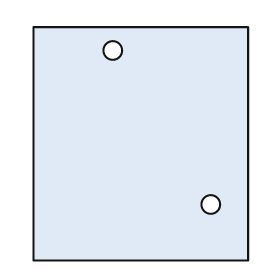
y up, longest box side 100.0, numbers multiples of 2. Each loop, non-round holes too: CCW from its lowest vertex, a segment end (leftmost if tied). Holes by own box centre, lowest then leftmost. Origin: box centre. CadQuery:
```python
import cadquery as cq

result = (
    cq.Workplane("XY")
    .moveTo(-46.0, -50.0)
    .lineTo(46.0, -50.0)
    .lineTo(46.0, 50.0)
    .lineTo(-46.0, 50.0)
    .close()
    .moveTo(30.0, -26.0)
    .circle(4.0)
    .moveTo(-12.0, 40.0)
    .circle(4.0)
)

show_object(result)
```